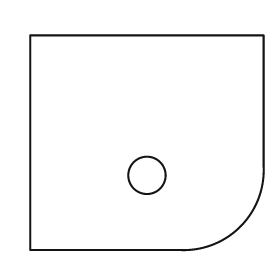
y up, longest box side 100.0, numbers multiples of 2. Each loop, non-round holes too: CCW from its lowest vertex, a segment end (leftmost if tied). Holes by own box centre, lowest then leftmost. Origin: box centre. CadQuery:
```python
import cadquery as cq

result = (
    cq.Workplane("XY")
    .moveTo(-50.0, -46.0)
    .lineTo(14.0, -46.0)
    .threePointArc((40.0, -36.0), (50.0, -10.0))
    .lineTo(50.0, 46.0)
    .lineTo(-50.0, 46.0)
    .close()
    .moveTo(0.0, -14.0)
    .circle(8.0)
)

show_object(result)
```